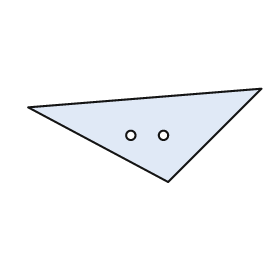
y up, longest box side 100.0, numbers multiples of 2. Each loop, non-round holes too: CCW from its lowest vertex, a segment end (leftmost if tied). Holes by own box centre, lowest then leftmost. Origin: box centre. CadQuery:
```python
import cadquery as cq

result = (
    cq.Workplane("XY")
    .moveTo(10.0, -20.0)
    .lineTo(50.0, 20.0)
    .lineTo(-50.0, 12.0)
    .close()
    .moveTo(-6.0, 0.0)
    .circle(2.0)
    .moveTo(8.0, 0.0)
    .circle(2.0)
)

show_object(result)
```